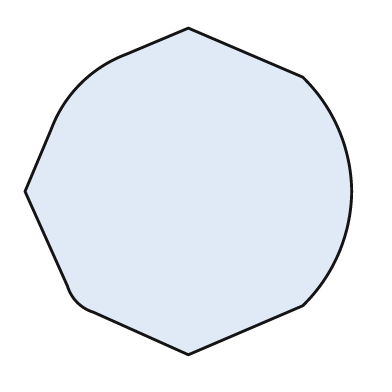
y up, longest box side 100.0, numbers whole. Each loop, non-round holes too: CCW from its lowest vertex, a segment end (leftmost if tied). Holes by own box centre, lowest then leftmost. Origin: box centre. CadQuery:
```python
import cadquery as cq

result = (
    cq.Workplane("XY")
    .moveTo(0.0, -50.0)
    .lineTo(35.0, -35.0)
    .threePointArc((46.0, -19.0), (50.0, 0.0))
    .threePointArc((46.0, 19.0), (35.0, 35.0))
    .lineTo(0.0, 50.0)
    .lineTo(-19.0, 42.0)
    .threePointArc((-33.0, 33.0), (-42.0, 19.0))
    .lineTo(-50.0, 0.0)
    .lineTo(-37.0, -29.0)
    .threePointArc((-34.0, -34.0), (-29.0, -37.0))
    .close()
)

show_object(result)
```